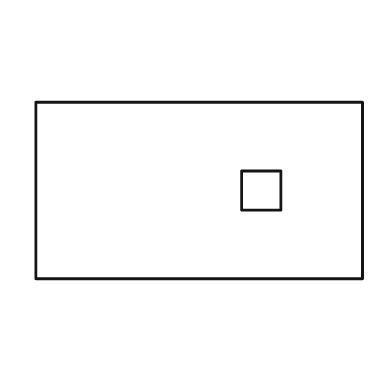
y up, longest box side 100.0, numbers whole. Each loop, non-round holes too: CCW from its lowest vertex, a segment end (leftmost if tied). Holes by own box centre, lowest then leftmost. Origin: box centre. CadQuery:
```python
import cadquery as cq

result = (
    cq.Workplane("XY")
    .moveTo(-50.0, -27.0)
    .lineTo(50.0, -27.0)
    .lineTo(50.0, 27.0)
    .lineTo(-50.0, 27.0)
    .close()
    .moveTo(13.0, -6.0)
    .lineTo(25.0, -6.0)
    .lineTo(25.0, 6.0)
    .lineTo(13.0, 6.0)
    .close()
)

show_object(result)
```